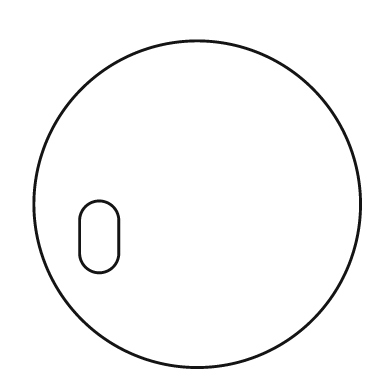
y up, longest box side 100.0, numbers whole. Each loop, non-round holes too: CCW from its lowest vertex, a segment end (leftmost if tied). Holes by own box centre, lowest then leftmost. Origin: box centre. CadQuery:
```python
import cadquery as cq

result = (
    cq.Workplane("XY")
    .moveTo(0.0, 0.0)
    .circle(50.0)
    .moveTo(-36.0, -15.0)
    .threePointArc((-30.0, -21.0), (-24.0, -15.0))
    .lineTo(-24.0, -5.0)
    .threePointArc((-30.0, 1.0), (-36.0, -5.0))
    .close()
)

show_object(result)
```